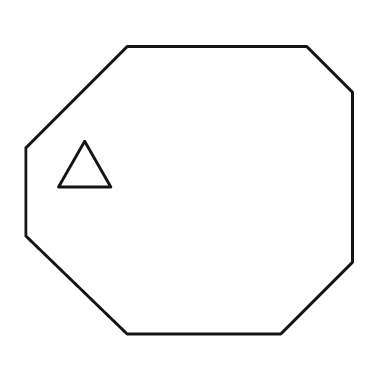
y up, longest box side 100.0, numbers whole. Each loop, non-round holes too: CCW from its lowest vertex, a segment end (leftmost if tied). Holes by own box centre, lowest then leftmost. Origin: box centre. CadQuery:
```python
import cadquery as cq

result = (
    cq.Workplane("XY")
    .moveTo(-19.0, -44.0)
    .lineTo(28.0, -44.0)
    .lineTo(50.0, -22.0)
    .lineTo(50.0, 30.0)
    .lineTo(36.0, 44.0)
    .lineTo(-19.0, 44.0)
    .lineTo(-50.0, 13.0)
    .lineTo(-50.0, -14.0)
    .close()
    .moveTo(-40.0, 1.0)
    .lineTo(-24.0, 1.0)
    .lineTo(-32.0, 15.0)
    .close()
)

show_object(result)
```